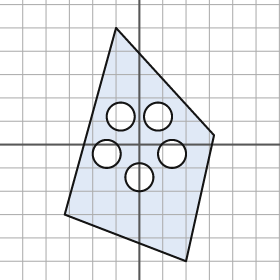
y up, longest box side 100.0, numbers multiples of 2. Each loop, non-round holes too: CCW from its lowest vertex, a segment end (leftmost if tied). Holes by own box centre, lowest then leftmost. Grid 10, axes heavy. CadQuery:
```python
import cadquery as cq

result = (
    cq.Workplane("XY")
    .moveTo(20.0, -50.0)
    .lineTo(32.0, 4.0)
    .lineTo(-10.0, 50.0)
    .lineTo(-32.0, -30.0)
    .close()
    .moveTo(0.0, -14.0)
    .circle(6.0)
    .moveTo(-14.0, -4.0)
    .circle(6.0)
    .moveTo(14.0, -4.0)
    .circle(6.0)
    .moveTo(-8.0, 12.0)
    .circle(6.0)
    .moveTo(8.0, 12.0)
    .circle(6.0)
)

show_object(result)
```